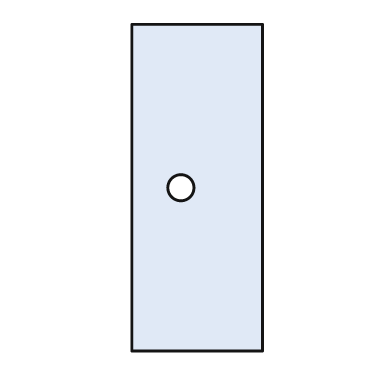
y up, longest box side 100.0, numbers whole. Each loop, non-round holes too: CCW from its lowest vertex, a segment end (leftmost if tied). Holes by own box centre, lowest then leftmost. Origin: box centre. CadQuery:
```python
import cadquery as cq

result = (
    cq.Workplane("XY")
    .moveTo(-20.0, -50.0)
    .lineTo(20.0, -50.0)
    .lineTo(20.0, 50.0)
    .lineTo(-20.0, 50.0)
    .close()
    .moveTo(-5.0, 0.0)
    .circle(4.0)
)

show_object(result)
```